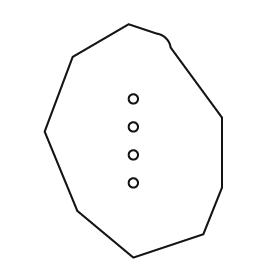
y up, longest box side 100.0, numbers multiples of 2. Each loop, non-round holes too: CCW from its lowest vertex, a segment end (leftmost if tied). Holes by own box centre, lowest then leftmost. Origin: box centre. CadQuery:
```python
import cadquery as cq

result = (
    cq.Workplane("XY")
    .moveTo(0.0, -50.0)
    .lineTo(30.0, -40.0)
    .lineTo(38.0, -20.0)
    .lineTo(38.0, 10.0)
    .lineTo(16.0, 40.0)
    .threePointArc((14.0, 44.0), (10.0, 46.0))
    .lineTo(-2.0, 50.0)
    .lineTo(-26.0, 36.0)
    .lineTo(-38.0, 4.0)
    .lineTo(-24.0, -30.0)
    .close()
    .moveTo(0.0, -18.0)
    .circle(2.0)
    .moveTo(0.0, -6.0)
    .circle(2.0)
    .moveTo(0.0, 6.0)
    .circle(2.0)
    .moveTo(0.0, 18.0)
    .circle(2.0)
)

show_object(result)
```